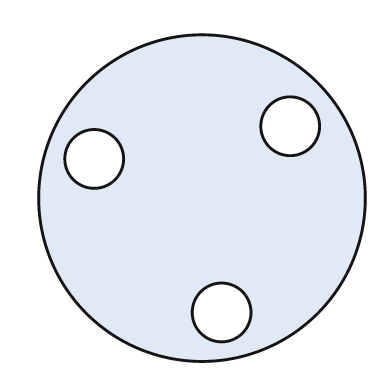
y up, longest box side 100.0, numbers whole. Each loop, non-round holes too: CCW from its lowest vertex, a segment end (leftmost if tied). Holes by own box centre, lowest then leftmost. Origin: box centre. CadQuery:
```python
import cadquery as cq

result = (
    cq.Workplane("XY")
    .moveTo(0.0, 0.0)
    .circle(50.0)
    .moveTo(6.0, -35.0)
    .circle(9.0)
    .moveTo(-33.0, 12.0)
    .circle(9.0)
    .moveTo(27.0, 22.0)
    .circle(9.0)
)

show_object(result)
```